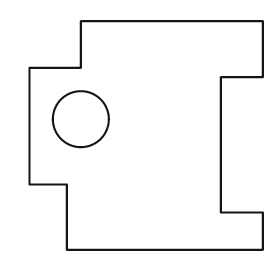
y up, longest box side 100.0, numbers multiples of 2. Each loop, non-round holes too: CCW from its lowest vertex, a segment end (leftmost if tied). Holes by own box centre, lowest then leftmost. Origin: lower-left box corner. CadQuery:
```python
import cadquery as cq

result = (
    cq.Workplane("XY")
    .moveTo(16.0, 0.0)
    .lineTo(100.0, 0.0)
    .lineTo(100.0, 16.0)
    .lineTo(82.0, 16.0)
    .lineTo(82.0, 74.0)
    .lineTo(100.0, 74.0)
    .lineTo(100.0, 98.0)
    .lineTo(22.0, 98.0)
    .lineTo(22.0, 78.0)
    .lineTo(0.0, 78.0)
    .lineTo(0.0, 28.0)
    .lineTo(16.0, 28.0)
    .close()
    .moveTo(22.0, 56.0)
    .circle(12.0)
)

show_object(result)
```